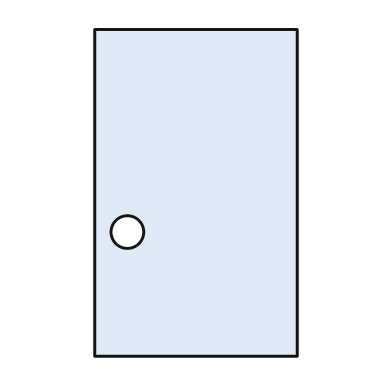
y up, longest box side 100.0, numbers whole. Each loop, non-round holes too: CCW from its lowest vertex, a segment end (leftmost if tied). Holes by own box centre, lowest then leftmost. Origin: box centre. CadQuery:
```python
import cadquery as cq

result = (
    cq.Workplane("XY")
    .moveTo(-31.0, -50.0)
    .lineTo(31.0, -50.0)
    .lineTo(31.0, 50.0)
    .lineTo(-31.0, 50.0)
    .close()
    .moveTo(-21.0, -12.0)
    .circle(5.0)
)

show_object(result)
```